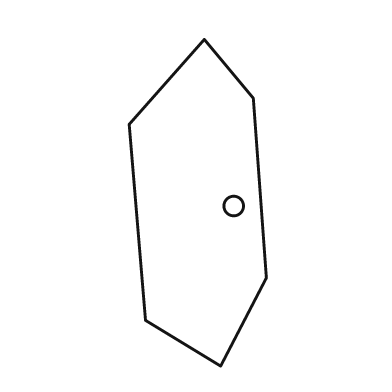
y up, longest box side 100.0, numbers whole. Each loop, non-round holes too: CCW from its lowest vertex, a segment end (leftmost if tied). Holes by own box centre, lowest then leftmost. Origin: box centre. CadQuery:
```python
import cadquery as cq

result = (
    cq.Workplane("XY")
    .moveTo(7.0, -50.0)
    .lineTo(21.0, -23.0)
    .lineTo(17.0, 32.0)
    .lineTo(2.0, 50.0)
    .lineTo(-21.0, 24.0)
    .lineTo(-16.0, -36.0)
    .close()
    .moveTo(11.0, -1.0)
    .circle(3.0)
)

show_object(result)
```